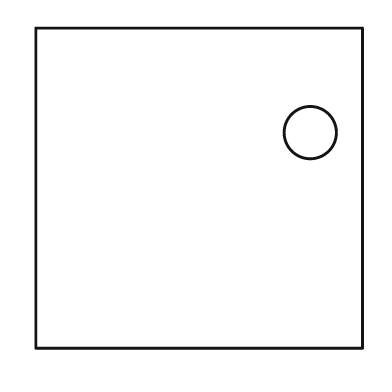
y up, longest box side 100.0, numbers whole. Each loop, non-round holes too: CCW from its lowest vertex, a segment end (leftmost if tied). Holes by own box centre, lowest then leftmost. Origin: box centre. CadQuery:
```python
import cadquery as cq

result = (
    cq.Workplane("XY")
    .moveTo(-50.0, -49.0)
    .lineTo(50.0, -49.0)
    .lineTo(50.0, 49.0)
    .lineTo(-50.0, 49.0)
    .close()
    .moveTo(34.0, 17.0)
    .circle(8.0)
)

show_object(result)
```